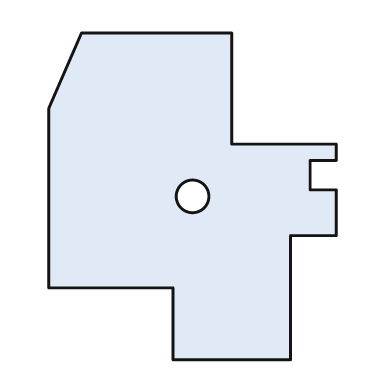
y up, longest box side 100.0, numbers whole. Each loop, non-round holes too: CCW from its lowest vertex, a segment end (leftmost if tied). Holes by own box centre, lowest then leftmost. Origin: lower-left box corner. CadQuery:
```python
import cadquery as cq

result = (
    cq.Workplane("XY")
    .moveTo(38.0, 0.0)
    .lineTo(74.0, 0.0)
    .lineTo(74.0, 38.0)
    .lineTo(88.0, 38.0)
    .lineTo(88.0, 52.0)
    .lineTo(80.0, 52.0)
    .lineTo(80.0, 61.0)
    .lineTo(88.0, 61.0)
    .lineTo(88.0, 66.0)
    .lineTo(56.0, 66.0)
    .lineTo(56.0, 100.0)
    .lineTo(10.0, 100.0)
    .lineTo(0.0, 77.0)
    .lineTo(0.0, 22.0)
    .lineTo(38.0, 22.0)
    .close()
    .moveTo(44.0, 50.0)
    .circle(5.0)
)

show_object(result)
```